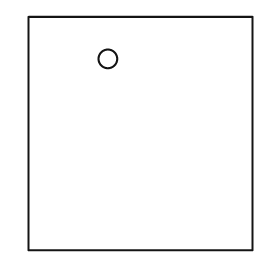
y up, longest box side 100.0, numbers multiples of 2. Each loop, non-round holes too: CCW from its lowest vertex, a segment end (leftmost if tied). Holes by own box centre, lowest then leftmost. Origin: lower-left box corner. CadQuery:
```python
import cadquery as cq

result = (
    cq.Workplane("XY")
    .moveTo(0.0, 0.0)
    .lineTo(96.0, 0.0)
    .lineTo(96.0, 100.0)
    .lineTo(0.0, 100.0)
    .close()
    .moveTo(34.0, 82.0)
    .circle(4.0)
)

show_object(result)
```